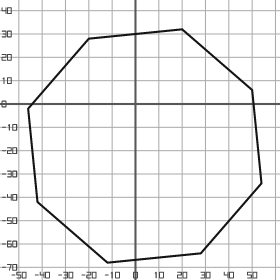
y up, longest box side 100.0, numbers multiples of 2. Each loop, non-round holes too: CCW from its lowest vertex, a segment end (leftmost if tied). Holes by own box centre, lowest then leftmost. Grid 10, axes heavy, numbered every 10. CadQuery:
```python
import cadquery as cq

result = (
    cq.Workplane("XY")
    .moveTo(-12.0, -68.0)
    .lineTo(28.0, -64.0)
    .lineTo(54.0, -34.0)
    .lineTo(50.0, 6.0)
    .lineTo(20.0, 32.0)
    .lineTo(-20.0, 28.0)
    .lineTo(-46.0, -2.0)
    .lineTo(-42.0, -42.0)
    .close()
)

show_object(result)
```